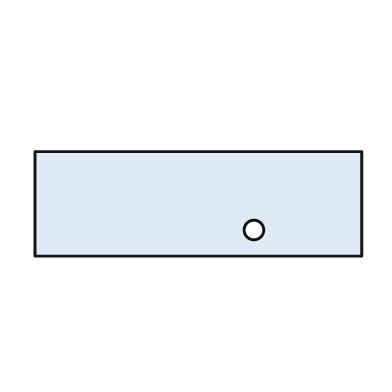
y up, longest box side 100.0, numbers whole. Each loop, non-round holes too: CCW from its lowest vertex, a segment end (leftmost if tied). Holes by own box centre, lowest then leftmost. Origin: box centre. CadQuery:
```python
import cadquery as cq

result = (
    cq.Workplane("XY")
    .moveTo(-50.0, -16.0)
    .lineTo(50.0, -16.0)
    .lineTo(50.0, 16.0)
    .lineTo(-50.0, 16.0)
    .close()
    .moveTo(17.0, -8.0)
    .circle(3.0)
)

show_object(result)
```